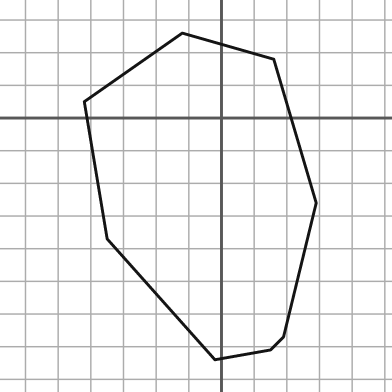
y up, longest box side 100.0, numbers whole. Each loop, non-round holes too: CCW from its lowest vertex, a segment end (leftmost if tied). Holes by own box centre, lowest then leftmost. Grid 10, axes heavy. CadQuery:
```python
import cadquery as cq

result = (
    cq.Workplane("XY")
    .moveTo(-2.0, -74.0)
    .lineTo(15.0, -71.0)
    .lineTo(19.0, -67.0)
    .lineTo(29.0, -26.0)
    .lineTo(16.0, 18.0)
    .lineTo(-12.0, 26.0)
    .lineTo(-42.0, 5.0)
    .lineTo(-35.0, -37.0)
    .close()
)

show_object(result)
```